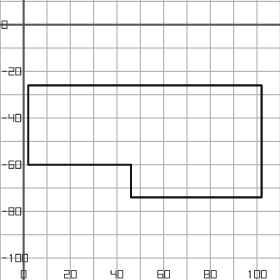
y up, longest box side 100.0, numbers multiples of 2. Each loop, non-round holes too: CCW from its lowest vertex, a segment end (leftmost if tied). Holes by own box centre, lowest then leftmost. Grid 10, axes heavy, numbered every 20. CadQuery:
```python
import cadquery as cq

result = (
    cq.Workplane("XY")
    .moveTo(46.0, -74.0)
    .lineTo(102.0, -74.0)
    .lineTo(102.0, -26.0)
    .lineTo(2.0, -26.0)
    .lineTo(2.0, -60.0)
    .lineTo(46.0, -60.0)
    .close()
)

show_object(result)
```